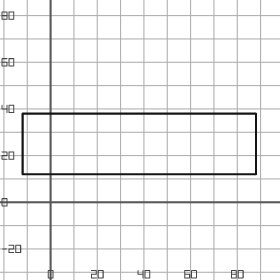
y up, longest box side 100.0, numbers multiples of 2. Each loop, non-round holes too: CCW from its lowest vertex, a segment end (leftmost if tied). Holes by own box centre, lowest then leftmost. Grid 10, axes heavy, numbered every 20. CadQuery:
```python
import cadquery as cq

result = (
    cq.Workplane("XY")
    .moveTo(-12.0, 12.0)
    .lineTo(88.0, 12.0)
    .lineTo(88.0, 38.0)
    .lineTo(-12.0, 38.0)
    .close()
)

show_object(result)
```